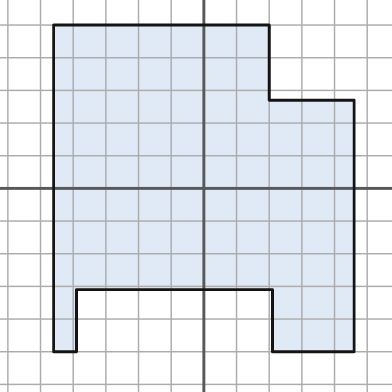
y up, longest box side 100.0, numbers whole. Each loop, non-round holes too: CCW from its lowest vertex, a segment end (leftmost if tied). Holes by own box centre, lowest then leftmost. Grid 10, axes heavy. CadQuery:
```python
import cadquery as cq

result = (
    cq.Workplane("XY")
    .moveTo(-46.0, -50.0)
    .lineTo(-39.0, -50.0)
    .lineTo(-39.0, -31.0)
    .lineTo(21.0, -31.0)
    .lineTo(21.0, -50.0)
    .lineTo(46.0, -50.0)
    .lineTo(46.0, 27.0)
    .lineTo(20.0, 27.0)
    .lineTo(20.0, 50.0)
    .lineTo(-46.0, 50.0)
    .close()
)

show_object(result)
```